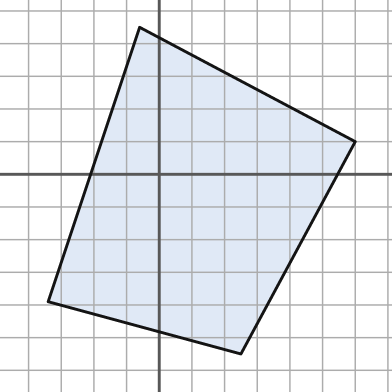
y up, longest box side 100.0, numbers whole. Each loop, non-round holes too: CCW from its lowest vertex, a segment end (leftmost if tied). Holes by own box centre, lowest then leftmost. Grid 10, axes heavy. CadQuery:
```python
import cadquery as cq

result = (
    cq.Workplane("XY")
    .moveTo(25.0, -55.0)
    .lineTo(60.0, 10.0)
    .lineTo(-6.0, 45.0)
    .lineTo(-34.0, -39.0)
    .close()
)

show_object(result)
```